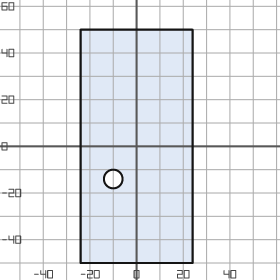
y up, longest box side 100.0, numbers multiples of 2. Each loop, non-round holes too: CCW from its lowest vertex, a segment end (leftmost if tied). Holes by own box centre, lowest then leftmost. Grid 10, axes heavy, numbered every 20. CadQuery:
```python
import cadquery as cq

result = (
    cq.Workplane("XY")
    .moveTo(-24.0, -50.0)
    .lineTo(24.0, -50.0)
    .lineTo(24.0, 50.0)
    .lineTo(-24.0, 50.0)
    .close()
    .moveTo(-10.0, -14.0)
    .circle(4.0)
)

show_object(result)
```